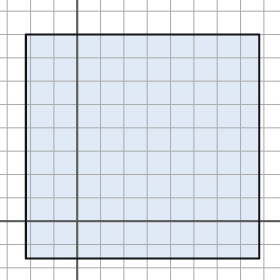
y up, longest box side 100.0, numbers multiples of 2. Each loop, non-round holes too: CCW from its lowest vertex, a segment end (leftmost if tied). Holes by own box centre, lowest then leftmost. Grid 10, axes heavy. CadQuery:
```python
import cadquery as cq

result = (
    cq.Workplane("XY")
    .moveTo(-22.0, -16.0)
    .lineTo(78.0, -16.0)
    .lineTo(78.0, 80.0)
    .lineTo(-22.0, 80.0)
    .close()
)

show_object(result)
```